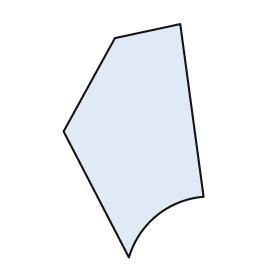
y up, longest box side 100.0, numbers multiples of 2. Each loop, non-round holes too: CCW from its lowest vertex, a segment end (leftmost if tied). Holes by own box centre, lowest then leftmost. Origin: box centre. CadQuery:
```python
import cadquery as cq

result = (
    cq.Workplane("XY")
    .moveTo(-2.0, -50.0)
    .threePointArc((10.0, -32.0), (30.0, -24.0))
    .lineTo(20.0, 50.0)
    .lineTo(-8.0, 44.0)
    .lineTo(-30.0, 4.0)
    .close()
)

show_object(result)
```